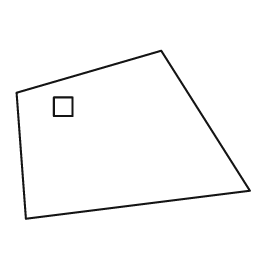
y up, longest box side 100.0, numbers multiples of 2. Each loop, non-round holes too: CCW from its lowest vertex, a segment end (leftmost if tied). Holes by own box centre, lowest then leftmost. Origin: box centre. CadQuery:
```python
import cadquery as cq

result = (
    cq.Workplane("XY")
    .moveTo(-46.0, -36.0)
    .lineTo(50.0, -24.0)
    .lineTo(12.0, 36.0)
    .lineTo(-50.0, 18.0)
    .close()
    .moveTo(-34.0, 8.0)
    .lineTo(-26.0, 8.0)
    .lineTo(-26.0, 16.0)
    .lineTo(-34.0, 16.0)
    .close()
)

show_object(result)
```